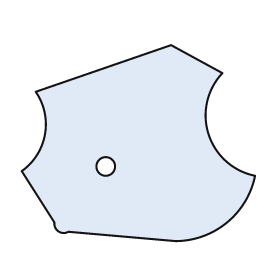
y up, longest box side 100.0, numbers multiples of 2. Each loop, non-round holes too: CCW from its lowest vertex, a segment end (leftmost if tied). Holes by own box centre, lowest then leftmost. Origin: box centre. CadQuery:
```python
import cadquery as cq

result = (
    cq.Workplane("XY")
    .moveTo(16.0, -42.0)
    .threePointArc((38.0, -34.0), (50.0, -14.0))
    .threePointArc((30.0, 4.0), (36.0, 30.0))
    .lineTo(14.0, 42.0)
    .lineTo(-44.0, 22.0)
    .threePointArc((-40.0, 4.0), (-50.0, -12.0))
    .lineTo(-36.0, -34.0)
    .threePointArc((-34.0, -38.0), (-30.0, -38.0))
    .close()
    .moveTo(-14.0, -10.0)
    .circle(4.0)
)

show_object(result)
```